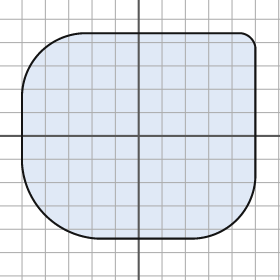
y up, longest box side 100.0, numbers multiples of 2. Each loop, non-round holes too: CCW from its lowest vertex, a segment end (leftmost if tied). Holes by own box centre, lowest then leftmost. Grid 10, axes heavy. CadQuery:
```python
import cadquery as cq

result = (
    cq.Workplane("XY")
    .moveTo(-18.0, -44.0)
    .lineTo(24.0, -44.0)
    .threePointArc((42.0, -36.0), (50.0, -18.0))
    .lineTo(50.0, 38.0)
    .threePointArc((48.0, 42.0), (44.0, 44.0))
    .lineTo(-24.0, 44.0)
    .threePointArc((-42.0, 36.0), (-50.0, 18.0))
    .lineTo(-50.0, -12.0)
    .threePointArc((-40.0, -34.0), (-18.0, -44.0))
    .close()
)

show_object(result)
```